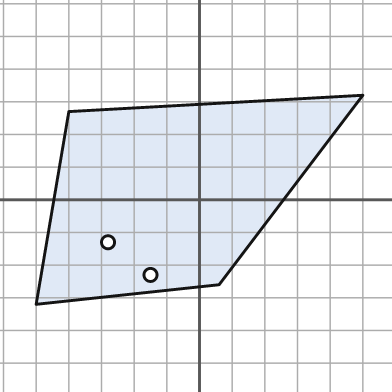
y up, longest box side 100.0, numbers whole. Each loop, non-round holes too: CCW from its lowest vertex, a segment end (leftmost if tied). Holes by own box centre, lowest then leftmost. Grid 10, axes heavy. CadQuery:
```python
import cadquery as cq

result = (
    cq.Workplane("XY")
    .moveTo(-50.0, -32.0)
    .lineTo(6.0, -26.0)
    .lineTo(50.0, 32.0)
    .lineTo(-40.0, 27.0)
    .close()
    .moveTo(-15.0, -23.0)
    .circle(2.0)
    .moveTo(-28.0, -13.0)
    .circle(2.0)
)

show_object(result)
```